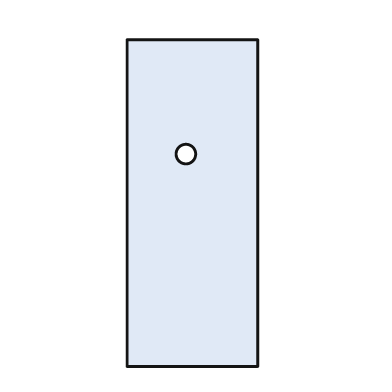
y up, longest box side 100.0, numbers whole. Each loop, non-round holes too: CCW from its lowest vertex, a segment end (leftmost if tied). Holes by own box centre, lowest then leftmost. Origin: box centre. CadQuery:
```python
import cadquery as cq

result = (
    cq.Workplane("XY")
    .moveTo(-20.0, -50.0)
    .lineTo(20.0, -50.0)
    .lineTo(20.0, 50.0)
    .lineTo(-20.0, 50.0)
    .close()
    .moveTo(-2.0, 15.0)
    .circle(3.0)
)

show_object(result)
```